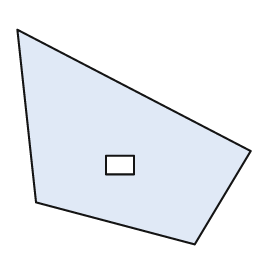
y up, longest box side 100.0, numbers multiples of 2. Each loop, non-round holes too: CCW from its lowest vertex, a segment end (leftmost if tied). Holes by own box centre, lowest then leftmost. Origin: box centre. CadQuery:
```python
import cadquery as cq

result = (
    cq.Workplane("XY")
    .moveTo(26.0, -46.0)
    .lineTo(50.0, -6.0)
    .lineTo(-50.0, 46.0)
    .lineTo(-42.0, -28.0)
    .close()
    .moveTo(-12.0, -16.0)
    .lineTo(0.0, -16.0)
    .lineTo(0.0, -8.0)
    .lineTo(-12.0, -8.0)
    .close()
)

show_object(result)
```